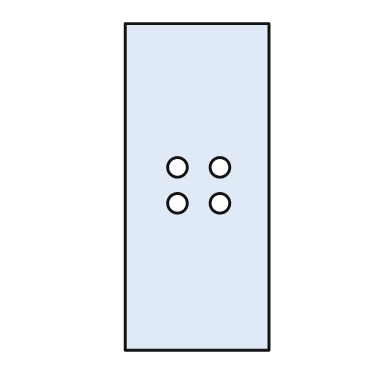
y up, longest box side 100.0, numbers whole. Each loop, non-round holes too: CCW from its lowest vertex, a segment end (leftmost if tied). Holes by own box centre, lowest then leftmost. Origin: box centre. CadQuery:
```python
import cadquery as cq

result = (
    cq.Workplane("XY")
    .moveTo(-22.0, -50.0)
    .lineTo(22.0, -50.0)
    .lineTo(22.0, 50.0)
    .lineTo(-22.0, 50.0)
    .close()
    .moveTo(-6.0, -5.0)
    .circle(3.0)
    .moveTo(7.0, -5.0)
    .circle(3.0)
    .moveTo(-6.0, 6.0)
    .circle(3.0)
    .moveTo(7.0, 6.0)
    .circle(3.0)
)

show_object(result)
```